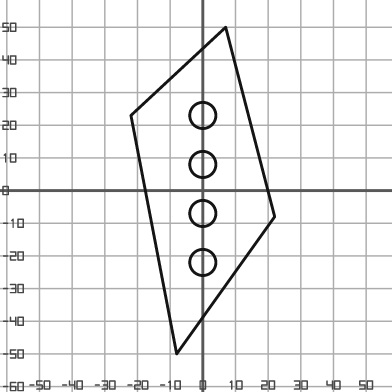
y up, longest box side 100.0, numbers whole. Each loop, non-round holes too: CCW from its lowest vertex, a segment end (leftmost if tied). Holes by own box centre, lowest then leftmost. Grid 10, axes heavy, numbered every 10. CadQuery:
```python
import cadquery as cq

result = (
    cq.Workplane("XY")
    .moveTo(-8.0, -50.0)
    .lineTo(22.0, -8.0)
    .lineTo(7.0, 50.0)
    .lineTo(-22.0, 23.0)
    .close()
    .moveTo(0.0, -22.0)
    .circle(4.0)
    .moveTo(0.0, -7.0)
    .circle(4.0)
    .moveTo(0.0, 8.0)
    .circle(4.0)
    .moveTo(0.0, 23.0)
    .circle(4.0)
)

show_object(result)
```